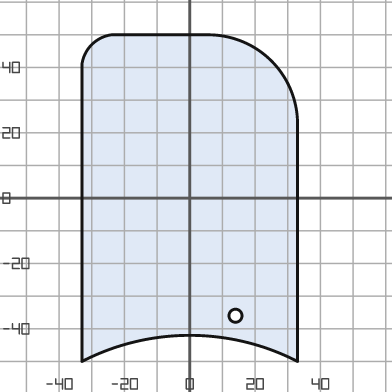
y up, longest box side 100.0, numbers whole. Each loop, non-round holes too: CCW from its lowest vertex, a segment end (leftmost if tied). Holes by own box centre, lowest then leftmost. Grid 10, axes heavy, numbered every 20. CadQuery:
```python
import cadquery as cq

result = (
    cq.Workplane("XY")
    .moveTo(-33.0, -50.0)
    .threePointArc((0.0, -42.0), (33.0, -50.0))
    .lineTo(33.0, 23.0)
    .threePointArc((25.0, 42.0), (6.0, 50.0))
    .lineTo(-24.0, 50.0)
    .threePointArc((-30.0, 47.0), (-33.0, 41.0))
    .close()
    .moveTo(14.0, -36.0)
    .circle(2.0)
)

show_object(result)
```